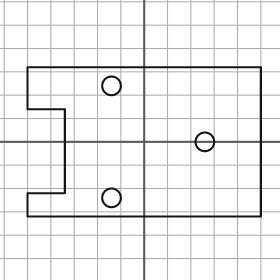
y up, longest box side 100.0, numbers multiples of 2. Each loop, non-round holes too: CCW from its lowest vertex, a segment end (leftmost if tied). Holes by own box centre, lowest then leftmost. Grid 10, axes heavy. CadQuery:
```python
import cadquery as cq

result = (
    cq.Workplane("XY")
    .moveTo(-50.0, -32.0)
    .lineTo(50.0, -32.0)
    .lineTo(50.0, 32.0)
    .lineTo(-50.0, 32.0)
    .lineTo(-50.0, 14.0)
    .lineTo(-34.0, 14.0)
    .lineTo(-34.0, -22.0)
    .lineTo(-50.0, -22.0)
    .close()
    .moveTo(-14.0, -24.0)
    .circle(4.0)
    .moveTo(26.0, 0.0)
    .circle(4.0)
    .moveTo(-14.0, 24.0)
    .circle(4.0)
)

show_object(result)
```